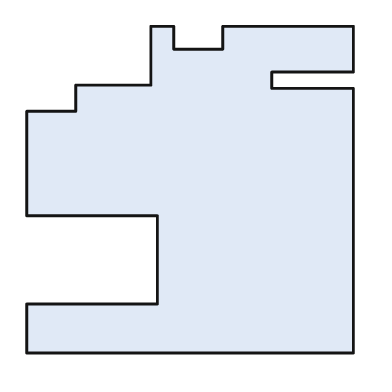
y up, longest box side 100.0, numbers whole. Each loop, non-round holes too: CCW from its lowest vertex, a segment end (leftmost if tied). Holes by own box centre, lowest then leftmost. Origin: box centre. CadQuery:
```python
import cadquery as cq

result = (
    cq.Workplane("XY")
    .moveTo(-50.0, -50.0)
    .lineTo(50.0, -50.0)
    .lineTo(50.0, 31.0)
    .lineTo(25.0, 31.0)
    .lineTo(25.0, 36.0)
    .lineTo(50.0, 36.0)
    .lineTo(50.0, 50.0)
    .lineTo(10.0, 50.0)
    .lineTo(10.0, 43.0)
    .lineTo(-5.0, 43.0)
    .lineTo(-5.0, 50.0)
    .lineTo(-12.0, 50.0)
    .lineTo(-12.0, 32.0)
    .lineTo(-35.0, 32.0)
    .lineTo(-35.0, 24.0)
    .lineTo(-50.0, 24.0)
    .lineTo(-50.0, -8.0)
    .lineTo(-10.0, -8.0)
    .lineTo(-10.0, -35.0)
    .lineTo(-50.0, -35.0)
    .close()
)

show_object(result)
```